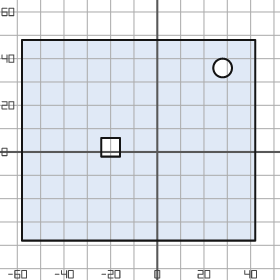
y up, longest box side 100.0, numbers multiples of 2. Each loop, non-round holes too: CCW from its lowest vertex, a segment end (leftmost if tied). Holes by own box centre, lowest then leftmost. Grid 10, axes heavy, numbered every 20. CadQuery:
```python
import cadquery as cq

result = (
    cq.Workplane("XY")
    .moveTo(-58.0, -38.0)
    .lineTo(42.0, -38.0)
    .lineTo(42.0, 48.0)
    .lineTo(-58.0, 48.0)
    .close()
    .moveTo(-24.0, -2.0)
    .lineTo(-16.0, -2.0)
    .lineTo(-16.0, 6.0)
    .lineTo(-24.0, 6.0)
    .close()
    .moveTo(28.0, 36.0)
    .circle(4.0)
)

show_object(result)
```